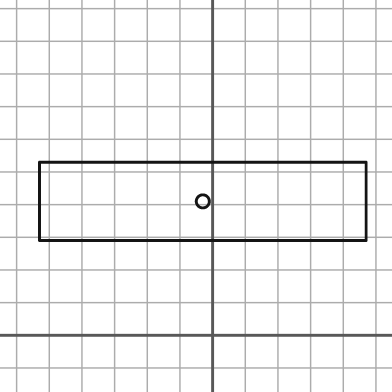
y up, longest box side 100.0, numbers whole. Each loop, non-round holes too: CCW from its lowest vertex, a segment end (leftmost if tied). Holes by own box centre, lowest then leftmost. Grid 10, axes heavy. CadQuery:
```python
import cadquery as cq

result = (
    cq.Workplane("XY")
    .moveTo(-53.0, 29.0)
    .lineTo(47.0, 29.0)
    .lineTo(47.0, 53.0)
    .lineTo(-53.0, 53.0)
    .close()
    .moveTo(-3.0, 41.0)
    .circle(2.0)
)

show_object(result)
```